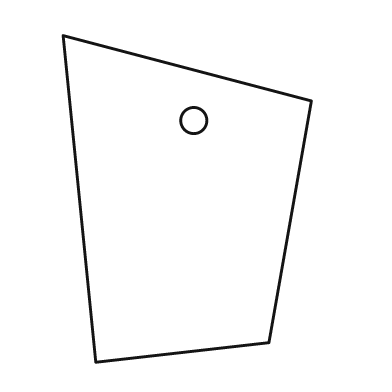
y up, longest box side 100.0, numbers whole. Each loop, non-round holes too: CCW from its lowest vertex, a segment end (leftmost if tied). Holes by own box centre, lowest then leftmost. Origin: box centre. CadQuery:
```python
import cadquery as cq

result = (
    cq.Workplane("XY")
    .moveTo(-28.0, -50.0)
    .lineTo(25.0, -44.0)
    .lineTo(38.0, 30.0)
    .lineTo(-38.0, 50.0)
    .close()
    .moveTo(2.0, 24.0)
    .circle(4.0)
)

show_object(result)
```